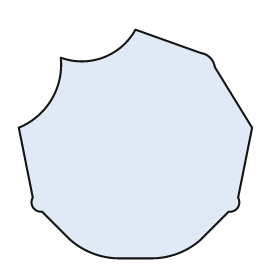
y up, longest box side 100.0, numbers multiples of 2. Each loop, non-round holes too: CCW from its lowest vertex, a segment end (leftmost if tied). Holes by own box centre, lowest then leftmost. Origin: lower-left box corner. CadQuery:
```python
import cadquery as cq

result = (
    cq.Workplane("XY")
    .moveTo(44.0, 0.0)
    .lineTo(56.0, 0.0)
    .threePointArc((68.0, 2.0), (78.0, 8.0))
    .lineTo(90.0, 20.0)
    .threePointArc((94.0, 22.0), (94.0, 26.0))
    .lineTo(100.0, 56.0)
    .lineTo(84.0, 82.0)
    .threePointArc((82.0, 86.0), (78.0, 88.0))
    .lineTo(50.0, 98.0)
    .threePointArc((36.0, 86.0), (18.0, 86.0))
    .threePointArc((14.0, 68.0), (0.0, 56.0))
    .lineTo(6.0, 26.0)
    .threePointArc((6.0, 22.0), (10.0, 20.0))
    .lineTo(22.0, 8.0)
    .threePointArc((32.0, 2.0), (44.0, 0.0))
    .close()
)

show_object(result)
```